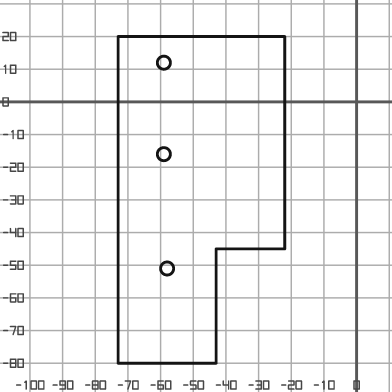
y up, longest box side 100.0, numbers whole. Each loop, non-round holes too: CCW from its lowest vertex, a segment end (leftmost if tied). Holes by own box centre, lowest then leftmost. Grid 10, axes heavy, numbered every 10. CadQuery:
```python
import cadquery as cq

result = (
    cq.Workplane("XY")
    .moveTo(-73.0, -80.0)
    .lineTo(-43.0, -80.0)
    .lineTo(-43.0, -45.0)
    .lineTo(-22.0, -45.0)
    .lineTo(-22.0, 20.0)
    .lineTo(-73.0, 20.0)
    .close()
    .moveTo(-58.0, -51.0)
    .circle(2.0)
    .moveTo(-59.0, -16.0)
    .circle(2.0)
    .moveTo(-59.0, 12.0)
    .circle(2.0)
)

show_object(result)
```